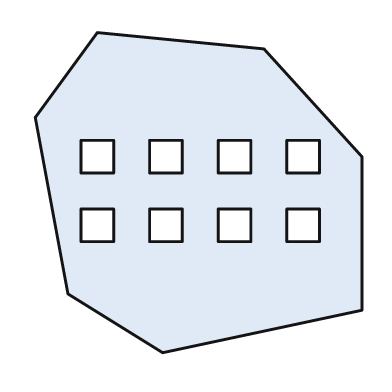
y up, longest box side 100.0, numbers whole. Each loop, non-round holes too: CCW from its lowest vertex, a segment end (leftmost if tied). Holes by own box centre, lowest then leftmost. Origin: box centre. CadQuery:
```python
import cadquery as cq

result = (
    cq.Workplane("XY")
    .moveTo(-11.0, -49.0)
    .lineTo(50.0, -36.0)
    .lineTo(50.0, 11.0)
    .lineTo(20.0, 44.0)
    .lineTo(-31.0, 49.0)
    .lineTo(-50.0, 23.0)
    .lineTo(-40.0, -31.0)
    .close()
    .moveTo(-36.0, -15.0)
    .lineTo(-26.0, -15.0)
    .lineTo(-26.0, -5.0)
    .lineTo(-36.0, -5.0)
    .close()
    .moveTo(-15.0, -15.0)
    .lineTo(-5.0, -15.0)
    .lineTo(-5.0, -5.0)
    .lineTo(-15.0, -5.0)
    .close()
    .moveTo(6.0, -15.0)
    .lineTo(16.0, -15.0)
    .lineTo(16.0, -5.0)
    .lineTo(6.0, -5.0)
    .close()
    .moveTo(27.0, -15.0)
    .lineTo(37.0, -15.0)
    .lineTo(37.0, -5.0)
    .lineTo(27.0, -5.0)
    .close()
    .moveTo(-36.0, 6.0)
    .lineTo(-26.0, 6.0)
    .lineTo(-26.0, 16.0)
    .lineTo(-36.0, 16.0)
    .close()
    .moveTo(-15.0, 6.0)
    .lineTo(-5.0, 6.0)
    .lineTo(-5.0, 16.0)
    .lineTo(-15.0, 16.0)
    .close()
    .moveTo(6.0, 6.0)
    .lineTo(16.0, 6.0)
    .lineTo(16.0, 16.0)
    .lineTo(6.0, 16.0)
    .close()
    .moveTo(27.0, 6.0)
    .lineTo(37.0, 6.0)
    .lineTo(37.0, 16.0)
    .lineTo(27.0, 16.0)
    .close()
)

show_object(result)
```